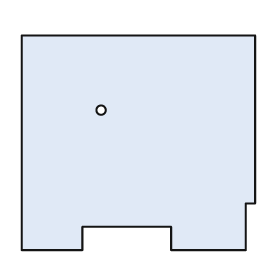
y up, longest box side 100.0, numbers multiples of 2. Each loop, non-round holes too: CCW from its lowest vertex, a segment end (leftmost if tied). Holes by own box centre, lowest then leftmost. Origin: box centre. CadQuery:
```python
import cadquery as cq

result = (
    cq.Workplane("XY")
    .moveTo(-50.0, -46.0)
    .lineTo(-24.0, -46.0)
    .lineTo(-24.0, -36.0)
    .lineTo(14.0, -36.0)
    .lineTo(14.0, -46.0)
    .lineTo(46.0, -46.0)
    .lineTo(46.0, -26.0)
    .lineTo(50.0, -26.0)
    .lineTo(50.0, 46.0)
    .lineTo(-50.0, 46.0)
    .close()
    .moveTo(-16.0, 14.0)
    .circle(2.0)
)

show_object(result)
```